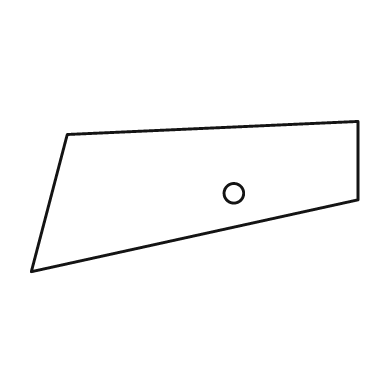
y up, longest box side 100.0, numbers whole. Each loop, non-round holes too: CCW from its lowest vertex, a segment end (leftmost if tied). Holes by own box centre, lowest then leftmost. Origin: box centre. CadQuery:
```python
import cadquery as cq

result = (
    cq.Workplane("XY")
    .moveTo(-50.0, -23.0)
    .lineTo(50.0, -1.0)
    .lineTo(50.0, 23.0)
    .lineTo(-39.0, 19.0)
    .close()
    .moveTo(12.0, 1.0)
    .circle(3.0)
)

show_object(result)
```